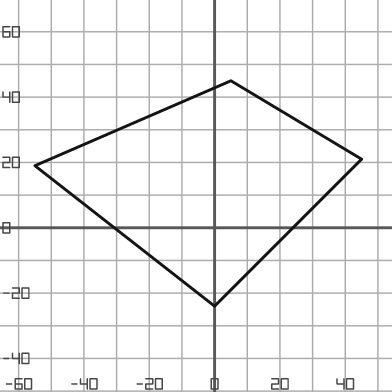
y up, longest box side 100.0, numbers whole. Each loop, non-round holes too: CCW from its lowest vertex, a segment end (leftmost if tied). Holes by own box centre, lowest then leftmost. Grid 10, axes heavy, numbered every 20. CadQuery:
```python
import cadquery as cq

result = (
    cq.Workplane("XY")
    .moveTo(0.0, -24.0)
    .lineTo(45.0, 21.0)
    .lineTo(5.0, 45.0)
    .lineTo(-55.0, 19.0)
    .close()
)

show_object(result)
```